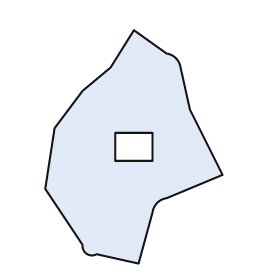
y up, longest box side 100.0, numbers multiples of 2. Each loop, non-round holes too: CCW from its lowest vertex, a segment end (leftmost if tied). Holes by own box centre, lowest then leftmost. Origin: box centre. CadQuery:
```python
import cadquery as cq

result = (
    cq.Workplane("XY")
    .moveTo(2.0, -50.0)
    .lineTo(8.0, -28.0)
    .threePointArc((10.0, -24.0), (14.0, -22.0))
    .lineTo(38.0, -12.0)
    .lineTo(24.0, 16.0)
    .lineTo(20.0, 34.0)
    .threePointArc((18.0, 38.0), (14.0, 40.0))
    .lineTo(0.0, 50.0)
    .lineTo(-10.0, 34.0)
    .lineTo(-22.0, 24.0)
    .lineTo(-34.0, 8.0)
    .lineTo(-38.0, -18.0)
    .lineTo(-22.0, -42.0)
    .threePointArc((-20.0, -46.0), (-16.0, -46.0))
    .close()
    .moveTo(-8.0, -6.0)
    .lineTo(8.0, -6.0)
    .lineTo(8.0, 6.0)
    .lineTo(-8.0, 6.0)
    .close()
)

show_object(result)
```